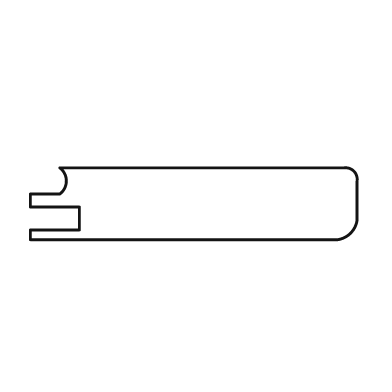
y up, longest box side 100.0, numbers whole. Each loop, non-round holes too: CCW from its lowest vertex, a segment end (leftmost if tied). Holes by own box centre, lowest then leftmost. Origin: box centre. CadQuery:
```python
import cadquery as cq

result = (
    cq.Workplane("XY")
    .moveTo(-50.0, -11.0)
    .lineTo(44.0, -11.0)
    .threePointArc((48.0, -9.0), (50.0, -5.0))
    .lineTo(50.0, 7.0)
    .threePointArc((49.0, 10.0), (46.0, 11.0))
    .lineTo(-41.0, 11.0)
    .threePointArc((-39.0, 7.0), (-41.0, 3.0))
    .lineTo(-50.0, 3.0)
    .lineTo(-50.0, -1.0)
    .lineTo(-35.0, -1.0)
    .lineTo(-35.0, -8.0)
    .lineTo(-50.0, -8.0)
    .close()
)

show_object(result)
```